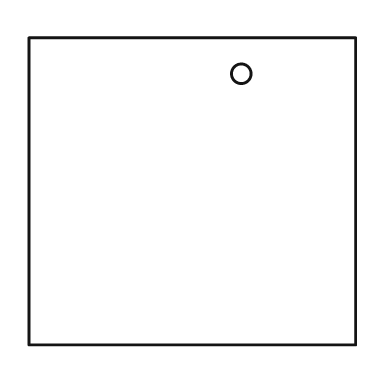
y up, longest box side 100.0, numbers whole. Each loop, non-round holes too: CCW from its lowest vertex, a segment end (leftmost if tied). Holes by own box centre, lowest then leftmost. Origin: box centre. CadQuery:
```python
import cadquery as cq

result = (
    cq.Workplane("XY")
    .moveTo(-50.0, -47.0)
    .lineTo(50.0, -47.0)
    .lineTo(50.0, 47.0)
    .lineTo(-50.0, 47.0)
    .close()
    .moveTo(15.0, 36.0)
    .circle(3.0)
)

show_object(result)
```